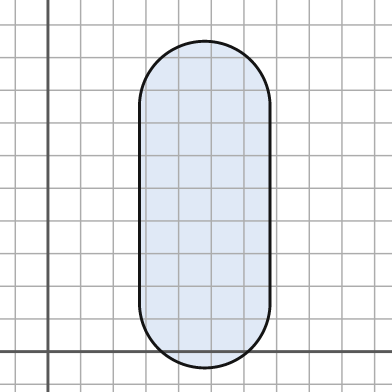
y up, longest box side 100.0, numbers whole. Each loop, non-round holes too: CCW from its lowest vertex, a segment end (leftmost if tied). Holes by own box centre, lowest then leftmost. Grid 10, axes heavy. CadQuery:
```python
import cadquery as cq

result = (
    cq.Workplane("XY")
    .moveTo(28.0, 15.0)
    .threePointArc((48.0, -5.0), (68.0, 15.0))
    .lineTo(68.0, 75.0)
    .threePointArc((48.0, 95.0), (28.0, 75.0))
    .close()
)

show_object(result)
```